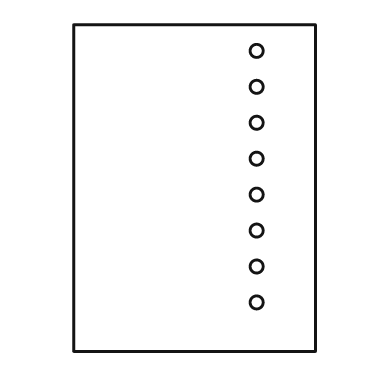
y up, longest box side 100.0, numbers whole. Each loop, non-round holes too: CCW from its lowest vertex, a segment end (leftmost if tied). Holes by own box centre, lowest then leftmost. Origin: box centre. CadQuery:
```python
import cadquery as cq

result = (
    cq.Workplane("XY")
    .moveTo(-37.0, -50.0)
    .lineTo(37.0, -50.0)
    .lineTo(37.0, 50.0)
    .lineTo(-37.0, 50.0)
    .close()
    .moveTo(19.0, -35.0)
    .circle(2.0)
    .moveTo(19.0, -24.0)
    .circle(2.0)
    .moveTo(19.0, -13.0)
    .circle(2.0)
    .moveTo(19.0, -2.0)
    .circle(2.0)
    .moveTo(19.0, 9.0)
    .circle(2.0)
    .moveTo(19.0, 20.0)
    .circle(2.0)
    .moveTo(19.0, 31.0)
    .circle(2.0)
    .moveTo(19.0, 42.0)
    .circle(2.0)
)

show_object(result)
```